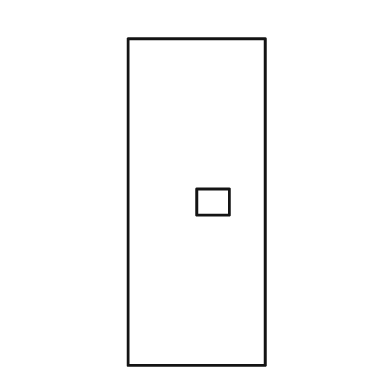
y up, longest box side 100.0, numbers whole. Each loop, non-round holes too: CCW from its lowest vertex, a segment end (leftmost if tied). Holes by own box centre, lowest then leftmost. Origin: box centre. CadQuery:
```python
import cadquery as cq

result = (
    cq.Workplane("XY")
    .moveTo(-21.0, -50.0)
    .lineTo(21.0, -50.0)
    .lineTo(21.0, 50.0)
    .lineTo(-21.0, 50.0)
    .close()
    .moveTo(0.0, -4.0)
    .lineTo(10.0, -4.0)
    .lineTo(10.0, 4.0)
    .lineTo(0.0, 4.0)
    .close()
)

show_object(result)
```